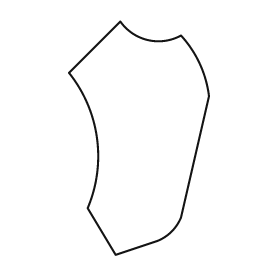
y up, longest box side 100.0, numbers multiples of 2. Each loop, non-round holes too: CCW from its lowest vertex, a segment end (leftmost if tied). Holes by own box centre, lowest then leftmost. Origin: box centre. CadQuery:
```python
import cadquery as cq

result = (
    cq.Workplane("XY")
    .moveTo(-10.0, -50.0)
    .lineTo(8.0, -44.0)
    .threePointArc((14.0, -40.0), (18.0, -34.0))
    .lineTo(30.0, 18.0)
    .threePointArc((26.0, 32.0), (18.0, 44.0))
    .threePointArc((4.0, 42.0), (-8.0, 50.0))
    .lineTo(-30.0, 28.0)
    .threePointArc((-18.0, 0.0), (-22.0, -30.0))
    .close()
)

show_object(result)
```